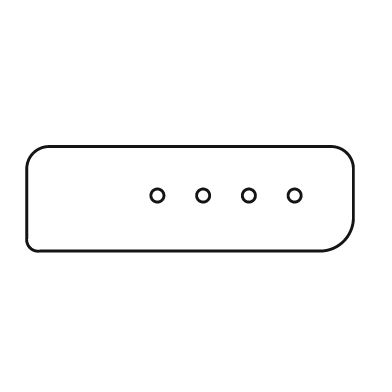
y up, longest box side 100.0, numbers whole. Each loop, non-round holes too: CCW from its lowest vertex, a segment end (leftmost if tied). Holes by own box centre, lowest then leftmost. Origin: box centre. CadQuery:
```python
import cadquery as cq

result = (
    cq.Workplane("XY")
    .moveTo(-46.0, -16.0)
    .lineTo(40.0, -16.0)
    .threePointArc((47.0, -13.0), (50.0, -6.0))
    .lineTo(50.0, 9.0)
    .threePointArc((48.0, 14.0), (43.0, 16.0))
    .lineTo(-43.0, 16.0)
    .threePointArc((-48.0, 14.0), (-50.0, 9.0))
    .lineTo(-50.0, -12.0)
    .threePointArc((-49.0, -15.0), (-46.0, -16.0))
    .close()
    .moveTo(-10.0, 1.0)
    .circle(2.0)
    .moveTo(4.0, 1.0)
    .circle(2.0)
    .moveTo(18.0, 1.0)
    .circle(2.0)
    .moveTo(32.0, 1.0)
    .circle(2.0)
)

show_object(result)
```